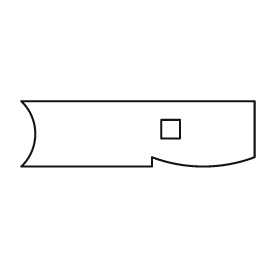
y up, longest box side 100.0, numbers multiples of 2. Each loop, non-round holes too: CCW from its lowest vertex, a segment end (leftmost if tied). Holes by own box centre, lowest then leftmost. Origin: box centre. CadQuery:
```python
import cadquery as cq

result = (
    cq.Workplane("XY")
    .moveTo(-50.0, -14.0)
    .lineTo(6.0, -14.0)
    .lineTo(6.0, -10.0)
    .threePointArc((28.0, -14.0), (50.0, -10.0))
    .lineTo(50.0, 14.0)
    .lineTo(-50.0, 14.0)
    .threePointArc((-44.0, 0.0), (-50.0, -14.0))
    .close()
    .moveTo(10.0, -2.0)
    .lineTo(18.0, -2.0)
    .lineTo(18.0, 6.0)
    .lineTo(10.0, 6.0)
    .close()
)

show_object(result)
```